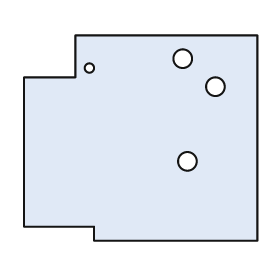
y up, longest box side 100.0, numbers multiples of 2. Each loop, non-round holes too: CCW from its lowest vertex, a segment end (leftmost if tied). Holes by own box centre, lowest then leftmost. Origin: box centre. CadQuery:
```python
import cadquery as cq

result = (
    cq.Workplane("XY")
    .moveTo(-20.0, -44.0)
    .lineTo(50.0, -44.0)
    .lineTo(50.0, 44.0)
    .lineTo(-28.0, 44.0)
    .lineTo(-28.0, 26.0)
    .lineTo(-50.0, 26.0)
    .lineTo(-50.0, -38.0)
    .lineTo(-20.0, -38.0)
    .close()
    .moveTo(20.0, -10.0)
    .circle(4.0)
    .moveTo(32.0, 22.0)
    .circle(4.0)
    .moveTo(-22.0, 30.0)
    .circle(2.0)
    .moveTo(18.0, 34.0)
    .circle(4.0)
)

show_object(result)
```